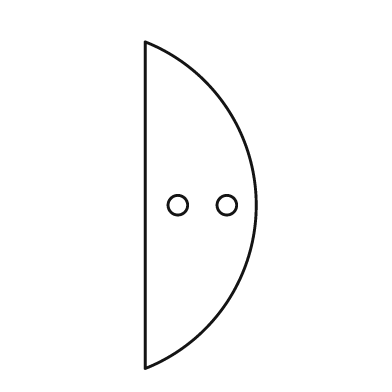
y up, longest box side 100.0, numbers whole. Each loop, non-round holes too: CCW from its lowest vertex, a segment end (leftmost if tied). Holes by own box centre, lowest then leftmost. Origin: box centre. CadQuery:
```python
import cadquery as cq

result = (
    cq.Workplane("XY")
    .moveTo(-17.0, -50.0)
    .threePointArc((17.0, 0.0), (-17.0, 50.0))
    .close()
    .moveTo(-7.0, 0.0)
    .circle(3.0)
    .moveTo(8.0, 0.0)
    .circle(3.0)
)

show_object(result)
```